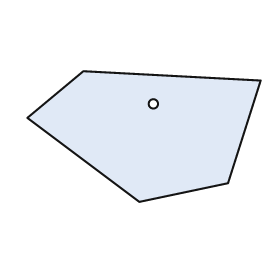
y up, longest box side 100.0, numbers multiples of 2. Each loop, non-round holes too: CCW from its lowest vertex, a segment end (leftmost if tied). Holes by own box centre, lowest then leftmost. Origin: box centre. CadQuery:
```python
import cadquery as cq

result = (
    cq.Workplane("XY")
    .moveTo(-2.0, -28.0)
    .lineTo(36.0, -20.0)
    .lineTo(50.0, 24.0)
    .lineTo(-26.0, 28.0)
    .lineTo(-50.0, 8.0)
    .close()
    .moveTo(4.0, 14.0)
    .circle(2.0)
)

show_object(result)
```